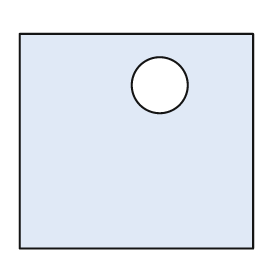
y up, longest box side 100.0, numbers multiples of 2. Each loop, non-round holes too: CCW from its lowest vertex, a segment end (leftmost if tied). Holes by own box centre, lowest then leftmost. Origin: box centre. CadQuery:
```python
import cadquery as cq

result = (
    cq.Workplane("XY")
    .moveTo(-50.0, -46.0)
    .lineTo(50.0, -46.0)
    .lineTo(50.0, 46.0)
    .lineTo(-50.0, 46.0)
    .close()
    .moveTo(10.0, 24.0)
    .circle(12.0)
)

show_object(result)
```